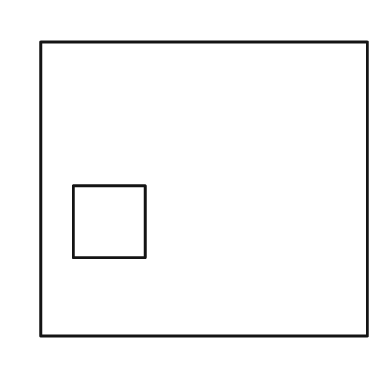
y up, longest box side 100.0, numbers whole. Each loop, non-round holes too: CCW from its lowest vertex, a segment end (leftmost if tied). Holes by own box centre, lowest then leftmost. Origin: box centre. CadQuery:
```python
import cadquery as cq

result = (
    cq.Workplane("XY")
    .moveTo(-50.0, -45.0)
    .lineTo(50.0, -45.0)
    .lineTo(50.0, 45.0)
    .lineTo(-50.0, 45.0)
    .close()
    .moveTo(-40.0, -21.0)
    .lineTo(-18.0, -21.0)
    .lineTo(-18.0, 1.0)
    .lineTo(-40.0, 1.0)
    .close()
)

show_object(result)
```